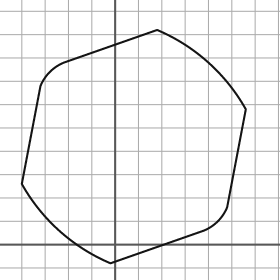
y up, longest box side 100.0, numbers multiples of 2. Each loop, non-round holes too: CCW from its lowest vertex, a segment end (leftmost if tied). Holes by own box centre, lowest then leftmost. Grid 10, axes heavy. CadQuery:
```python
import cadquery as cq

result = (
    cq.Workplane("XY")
    .moveTo(-2.0, -8.0)
    .lineTo(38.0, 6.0)
    .threePointArc((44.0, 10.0), (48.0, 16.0))
    .lineTo(56.0, 58.0)
    .threePointArc((40.0, 78.0), (18.0, 92.0))
    .lineTo(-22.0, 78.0)
    .threePointArc((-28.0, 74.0), (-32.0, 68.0))
    .lineTo(-40.0, 26.0)
    .threePointArc((-24.0, 6.0), (-2.0, -8.0))
    .close()
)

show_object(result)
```